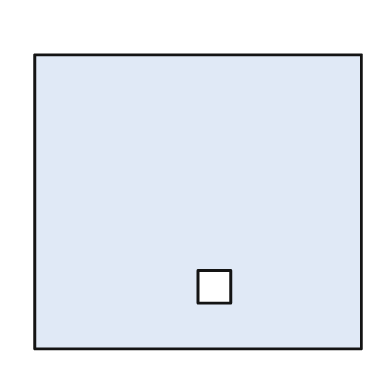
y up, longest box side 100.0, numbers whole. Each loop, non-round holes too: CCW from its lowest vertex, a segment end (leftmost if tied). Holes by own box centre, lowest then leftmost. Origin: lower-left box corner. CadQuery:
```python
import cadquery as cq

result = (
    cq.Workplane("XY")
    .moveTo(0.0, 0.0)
    .lineTo(100.0, 0.0)
    .lineTo(100.0, 90.0)
    .lineTo(0.0, 90.0)
    .close()
    .moveTo(50.0, 14.0)
    .lineTo(60.0, 14.0)
    .lineTo(60.0, 24.0)
    .lineTo(50.0, 24.0)
    .close()
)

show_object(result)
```